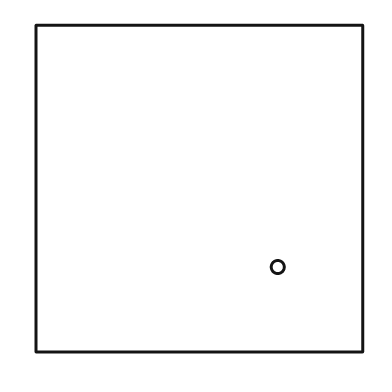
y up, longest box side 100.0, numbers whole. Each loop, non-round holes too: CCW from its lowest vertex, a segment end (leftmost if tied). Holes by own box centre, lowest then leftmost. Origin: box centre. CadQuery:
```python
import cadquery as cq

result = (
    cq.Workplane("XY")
    .moveTo(-50.0, -50.0)
    .lineTo(50.0, -50.0)
    .lineTo(50.0, 50.0)
    .lineTo(-50.0, 50.0)
    .close()
    .moveTo(24.0, -24.0)
    .circle(2.0)
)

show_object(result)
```